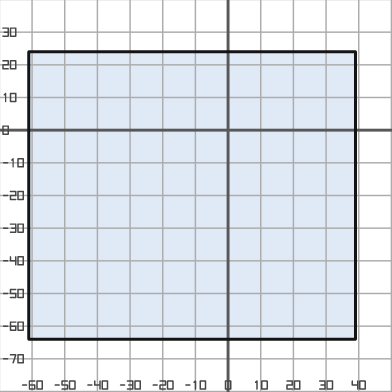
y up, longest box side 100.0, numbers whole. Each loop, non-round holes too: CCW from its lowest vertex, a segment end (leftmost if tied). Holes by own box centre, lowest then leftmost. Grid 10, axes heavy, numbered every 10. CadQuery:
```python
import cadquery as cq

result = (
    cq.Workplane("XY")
    .moveTo(-61.0, -64.0)
    .lineTo(39.0, -64.0)
    .lineTo(39.0, 24.0)
    .lineTo(-61.0, 24.0)
    .close()
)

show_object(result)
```